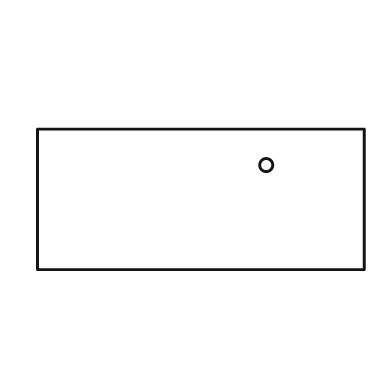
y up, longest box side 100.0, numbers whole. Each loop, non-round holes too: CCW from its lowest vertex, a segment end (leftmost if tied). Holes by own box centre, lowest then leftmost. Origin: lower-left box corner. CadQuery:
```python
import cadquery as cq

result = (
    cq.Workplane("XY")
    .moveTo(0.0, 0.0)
    .lineTo(100.0, 0.0)
    .lineTo(100.0, 43.0)
    .lineTo(0.0, 43.0)
    .close()
    .moveTo(70.0, 32.0)
    .circle(2.0)
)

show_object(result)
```